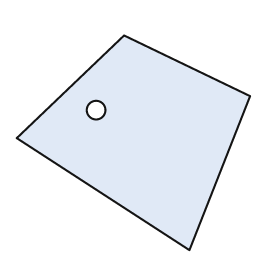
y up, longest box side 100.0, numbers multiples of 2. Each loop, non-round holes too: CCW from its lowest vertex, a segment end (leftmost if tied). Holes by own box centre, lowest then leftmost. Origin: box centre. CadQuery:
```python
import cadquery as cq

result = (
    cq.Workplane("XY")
    .moveTo(24.0, -46.0)
    .lineTo(50.0, 20.0)
    .lineTo(-4.0, 46.0)
    .lineTo(-50.0, 2.0)
    .close()
    .moveTo(-16.0, 14.0)
    .circle(4.0)
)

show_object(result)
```